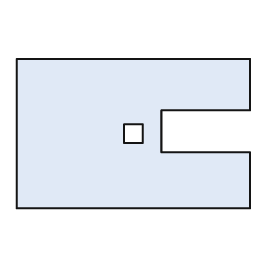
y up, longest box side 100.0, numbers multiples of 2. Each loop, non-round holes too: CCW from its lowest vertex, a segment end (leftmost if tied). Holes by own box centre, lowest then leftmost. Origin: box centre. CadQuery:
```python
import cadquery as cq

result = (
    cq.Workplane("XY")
    .moveTo(-50.0, -32.0)
    .lineTo(50.0, -32.0)
    .lineTo(50.0, -8.0)
    .lineTo(12.0, -8.0)
    .lineTo(12.0, 10.0)
    .lineTo(50.0, 10.0)
    .lineTo(50.0, 32.0)
    .lineTo(-50.0, 32.0)
    .close()
    .moveTo(-4.0, -4.0)
    .lineTo(4.0, -4.0)
    .lineTo(4.0, 4.0)
    .lineTo(-4.0, 4.0)
    .close()
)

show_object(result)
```